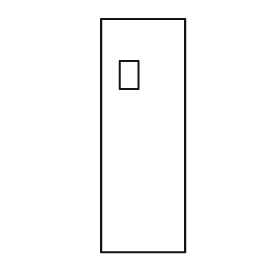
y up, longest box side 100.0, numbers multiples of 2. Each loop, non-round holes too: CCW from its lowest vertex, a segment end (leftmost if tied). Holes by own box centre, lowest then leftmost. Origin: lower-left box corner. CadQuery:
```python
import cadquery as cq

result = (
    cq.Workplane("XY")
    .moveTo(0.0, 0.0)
    .lineTo(36.0, 0.0)
    .lineTo(36.0, 100.0)
    .lineTo(0.0, 100.0)
    .close()
    .moveTo(8.0, 70.0)
    .lineTo(16.0, 70.0)
    .lineTo(16.0, 82.0)
    .lineTo(8.0, 82.0)
    .close()
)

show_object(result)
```